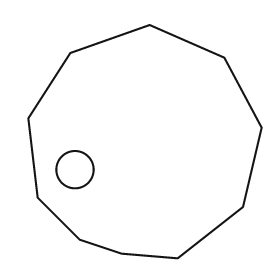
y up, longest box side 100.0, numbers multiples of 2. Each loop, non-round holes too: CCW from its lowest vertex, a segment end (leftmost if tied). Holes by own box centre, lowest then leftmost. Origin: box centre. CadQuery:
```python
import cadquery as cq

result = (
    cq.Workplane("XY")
    .moveTo(14.0, -50.0)
    .lineTo(42.0, -28.0)
    .lineTo(50.0, 6.0)
    .lineTo(34.0, 36.0)
    .lineTo(2.0, 50.0)
    .lineTo(-32.0, 38.0)
    .lineTo(-50.0, 10.0)
    .lineTo(-46.0, -24.0)
    .lineTo(-28.0, -42.0)
    .lineTo(-10.0, -48.0)
    .close()
    .moveTo(-30.0, -12.0)
    .circle(8.0)
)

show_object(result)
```